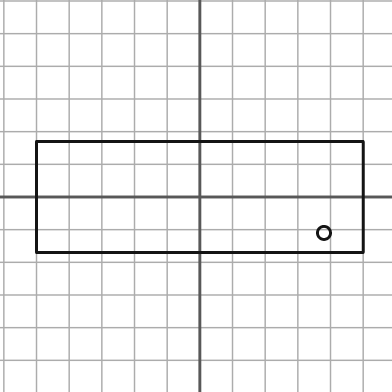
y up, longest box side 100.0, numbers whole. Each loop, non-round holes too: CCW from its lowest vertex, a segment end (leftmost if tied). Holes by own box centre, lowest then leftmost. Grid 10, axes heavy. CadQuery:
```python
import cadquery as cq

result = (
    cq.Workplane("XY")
    .moveTo(-50.0, -17.0)
    .lineTo(50.0, -17.0)
    .lineTo(50.0, 17.0)
    .lineTo(-50.0, 17.0)
    .close()
    .moveTo(38.0, -11.0)
    .circle(2.0)
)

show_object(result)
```